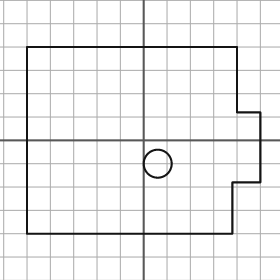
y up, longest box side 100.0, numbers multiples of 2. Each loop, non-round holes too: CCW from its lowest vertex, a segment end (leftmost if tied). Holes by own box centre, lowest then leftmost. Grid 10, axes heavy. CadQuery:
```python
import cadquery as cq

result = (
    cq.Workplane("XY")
    .moveTo(-50.0, -40.0)
    .lineTo(38.0, -40.0)
    .lineTo(38.0, -18.0)
    .lineTo(50.0, -18.0)
    .lineTo(50.0, 12.0)
    .lineTo(40.0, 12.0)
    .lineTo(40.0, 40.0)
    .lineTo(-50.0, 40.0)
    .close()
    .moveTo(6.0, -10.0)
    .circle(6.0)
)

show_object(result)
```